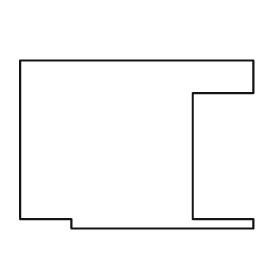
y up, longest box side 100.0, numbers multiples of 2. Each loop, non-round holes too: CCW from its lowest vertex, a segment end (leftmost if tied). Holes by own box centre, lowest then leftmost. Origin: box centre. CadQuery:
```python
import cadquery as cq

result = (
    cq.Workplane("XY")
    .moveTo(-28.0, -36.0)
    .lineTo(50.0, -36.0)
    .lineTo(50.0, -32.0)
    .lineTo(24.0, -32.0)
    .lineTo(24.0, 22.0)
    .lineTo(50.0, 22.0)
    .lineTo(50.0, 36.0)
    .lineTo(-50.0, 36.0)
    .lineTo(-50.0, -32.0)
    .lineTo(-28.0, -32.0)
    .close()
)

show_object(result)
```